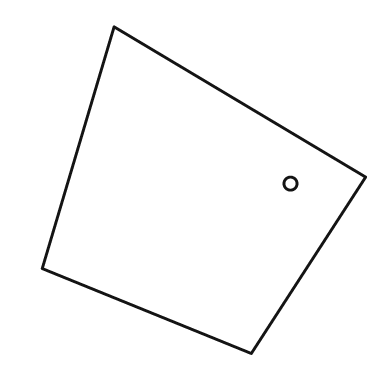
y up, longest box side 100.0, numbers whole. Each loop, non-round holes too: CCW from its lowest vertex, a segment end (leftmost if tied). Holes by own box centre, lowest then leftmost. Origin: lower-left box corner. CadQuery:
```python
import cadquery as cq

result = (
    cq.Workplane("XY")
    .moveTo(64.0, 0.0)
    .lineTo(99.0, 54.0)
    .lineTo(22.0, 100.0)
    .lineTo(0.0, 26.0)
    .close()
    .moveTo(76.0, 52.0)
    .circle(2.0)
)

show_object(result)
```